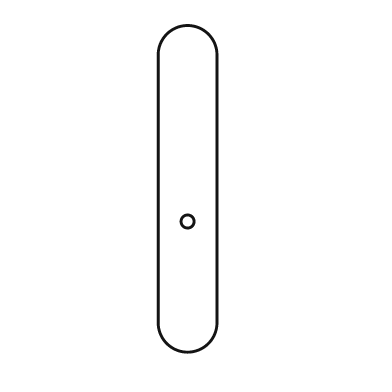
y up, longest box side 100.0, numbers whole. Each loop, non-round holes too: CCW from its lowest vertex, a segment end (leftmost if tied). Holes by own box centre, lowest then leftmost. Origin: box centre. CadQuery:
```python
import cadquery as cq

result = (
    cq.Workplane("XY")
    .moveTo(-9.0, -41.0)
    .threePointArc((0.0, -50.0), (9.0, -41.0))
    .lineTo(9.0, 41.0)
    .threePointArc((0.0, 50.0), (-9.0, 41.0))
    .close()
    .moveTo(0.0, -10.0)
    .circle(2.0)
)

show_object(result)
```